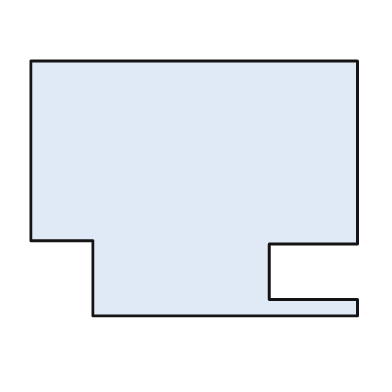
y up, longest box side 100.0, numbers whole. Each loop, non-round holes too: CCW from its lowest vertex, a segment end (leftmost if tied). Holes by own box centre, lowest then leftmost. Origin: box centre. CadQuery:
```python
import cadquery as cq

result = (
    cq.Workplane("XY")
    .moveTo(-31.0, -39.0)
    .lineTo(50.0, -39.0)
    .lineTo(50.0, -34.0)
    .lineTo(23.0, -34.0)
    .lineTo(23.0, -17.0)
    .lineTo(50.0, -17.0)
    .lineTo(50.0, 39.0)
    .lineTo(-50.0, 39.0)
    .lineTo(-50.0, -16.0)
    .lineTo(-31.0, -16.0)
    .close()
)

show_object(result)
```